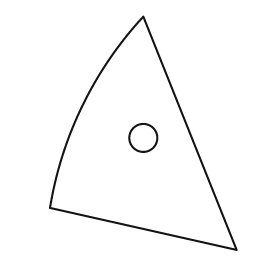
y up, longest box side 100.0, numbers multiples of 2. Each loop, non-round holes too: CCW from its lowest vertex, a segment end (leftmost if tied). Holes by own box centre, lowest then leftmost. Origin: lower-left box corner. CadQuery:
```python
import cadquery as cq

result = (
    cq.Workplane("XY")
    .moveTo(80.0, 0.0)
    .lineTo(40.0, 100.0)
    .threePointArc((14.0, 62.0), (0.0, 18.0))
    .close()
    .moveTo(40.0, 48.0)
    .circle(6.0)
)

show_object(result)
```